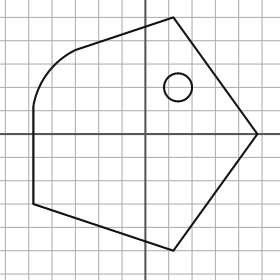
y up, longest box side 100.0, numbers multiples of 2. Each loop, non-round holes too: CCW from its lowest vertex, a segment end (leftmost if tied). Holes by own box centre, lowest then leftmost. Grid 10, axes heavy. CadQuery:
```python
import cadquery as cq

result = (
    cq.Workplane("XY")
    .moveTo(12.0, -50.0)
    .lineTo(48.0, 0.0)
    .lineTo(12.0, 50.0)
    .lineTo(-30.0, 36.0)
    .threePointArc((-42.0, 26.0), (-48.0, 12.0))
    .lineTo(-48.0, -30.0)
    .close()
    .moveTo(14.0, 20.0)
    .circle(6.0)
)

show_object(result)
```